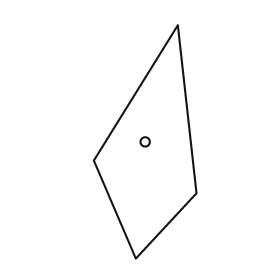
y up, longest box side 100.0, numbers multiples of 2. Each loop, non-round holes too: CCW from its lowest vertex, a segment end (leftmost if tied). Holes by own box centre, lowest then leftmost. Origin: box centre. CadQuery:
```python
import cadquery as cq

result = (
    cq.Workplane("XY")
    .moveTo(-4.0, -50.0)
    .lineTo(22.0, -22.0)
    .lineTo(14.0, 50.0)
    .lineTo(-22.0, -8.0)
    .close()
    .moveTo(0.0, 0.0)
    .circle(2.0)
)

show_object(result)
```